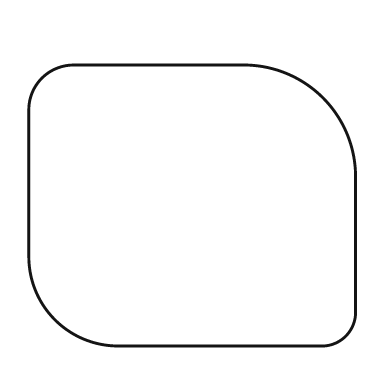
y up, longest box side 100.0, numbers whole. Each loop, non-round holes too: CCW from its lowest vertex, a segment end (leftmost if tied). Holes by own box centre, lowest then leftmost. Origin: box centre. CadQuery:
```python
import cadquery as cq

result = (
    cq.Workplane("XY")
    .moveTo(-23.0, -43.0)
    .lineTo(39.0, -43.0)
    .threePointArc((47.0, -40.0), (50.0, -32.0))
    .lineTo(50.0, 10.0)
    .threePointArc((40.0, 33.0), (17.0, 43.0))
    .lineTo(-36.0, 43.0)
    .threePointArc((-46.0, 39.0), (-50.0, 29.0))
    .lineTo(-50.0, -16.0)
    .threePointArc((-42.0, -35.0), (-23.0, -43.0))
    .close()
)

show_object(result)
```